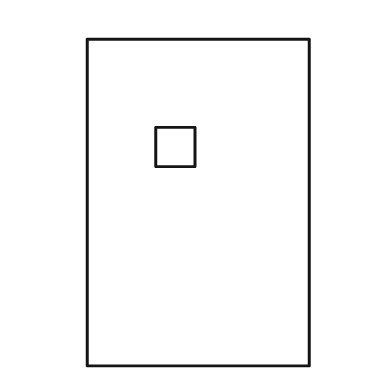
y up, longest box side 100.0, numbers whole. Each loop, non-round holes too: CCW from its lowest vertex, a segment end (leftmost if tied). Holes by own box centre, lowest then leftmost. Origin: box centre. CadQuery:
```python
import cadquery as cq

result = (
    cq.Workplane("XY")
    .moveTo(-34.0, -50.0)
    .lineTo(34.0, -50.0)
    .lineTo(34.0, 50.0)
    .lineTo(-34.0, 50.0)
    .close()
    .moveTo(-13.0, 11.0)
    .lineTo(-1.0, 11.0)
    .lineTo(-1.0, 23.0)
    .lineTo(-13.0, 23.0)
    .close()
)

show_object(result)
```